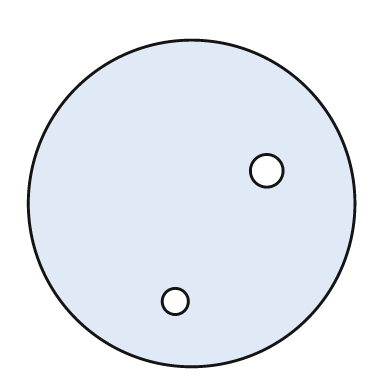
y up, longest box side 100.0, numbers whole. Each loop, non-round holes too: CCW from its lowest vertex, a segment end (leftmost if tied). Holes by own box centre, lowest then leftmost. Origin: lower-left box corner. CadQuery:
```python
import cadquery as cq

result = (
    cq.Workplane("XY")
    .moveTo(50.0, 50.0)
    .circle(50.0)
    .moveTo(45.0, 20.0)
    .circle(4.0)
    .moveTo(73.0, 60.0)
    .circle(5.0)
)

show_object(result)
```